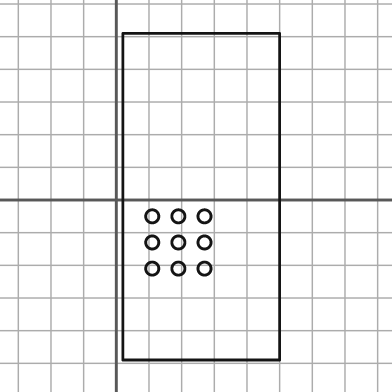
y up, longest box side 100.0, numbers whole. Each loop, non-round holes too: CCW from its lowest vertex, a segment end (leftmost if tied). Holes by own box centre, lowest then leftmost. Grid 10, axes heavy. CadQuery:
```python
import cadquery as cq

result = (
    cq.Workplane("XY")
    .moveTo(2.0, -49.0)
    .lineTo(50.0, -49.0)
    .lineTo(50.0, 51.0)
    .lineTo(2.0, 51.0)
    .close()
    .moveTo(11.0, -21.0)
    .circle(2.0)
    .moveTo(19.0, -21.0)
    .circle(2.0)
    .moveTo(27.0, -21.0)
    .circle(2.0)
    .moveTo(11.0, -13.0)
    .circle(2.0)
    .moveTo(19.0, -13.0)
    .circle(2.0)
    .moveTo(27.0, -13.0)
    .circle(2.0)
    .moveTo(11.0, -5.0)
    .circle(2.0)
    .moveTo(19.0, -5.0)
    .circle(2.0)
    .moveTo(27.0, -5.0)
    .circle(2.0)
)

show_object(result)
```